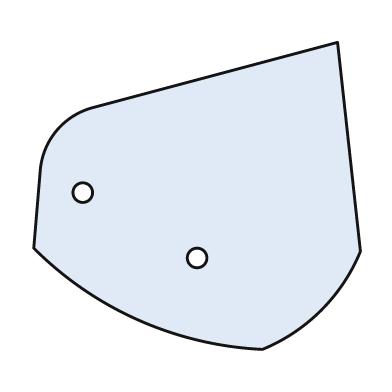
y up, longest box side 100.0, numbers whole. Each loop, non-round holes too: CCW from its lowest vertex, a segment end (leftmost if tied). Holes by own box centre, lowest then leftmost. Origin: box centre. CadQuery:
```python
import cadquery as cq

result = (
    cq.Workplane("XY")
    .moveTo(20.0, -47.0)
    .threePointArc((38.0, -35.0), (50.0, -17.0))
    .lineTo(43.0, 47.0)
    .lineTo(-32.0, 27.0)
    .threePointArc((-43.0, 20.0), (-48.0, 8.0))
    .lineTo(-50.0, -16.0)
    .threePointArc((-18.0, -38.0), (20.0, -47.0))
    .close()
    .moveTo(0.0, -19.0)
    .circle(3.0)
    .moveTo(-35.0, 1.0)
    .circle(3.0)
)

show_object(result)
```